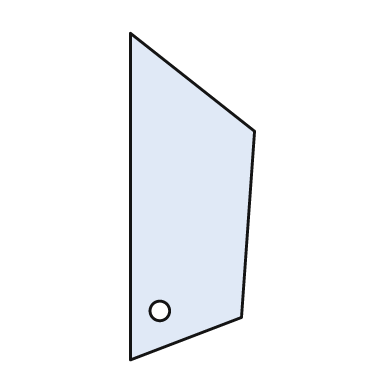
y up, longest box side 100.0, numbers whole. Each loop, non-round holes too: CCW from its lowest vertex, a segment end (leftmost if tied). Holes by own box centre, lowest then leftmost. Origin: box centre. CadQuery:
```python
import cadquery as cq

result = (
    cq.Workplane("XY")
    .moveTo(-19.0, -50.0)
    .lineTo(15.0, -37.0)
    .lineTo(19.0, 20.0)
    .lineTo(-19.0, 50.0)
    .close()
    .moveTo(-10.0, -35.0)
    .circle(3.0)
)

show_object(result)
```